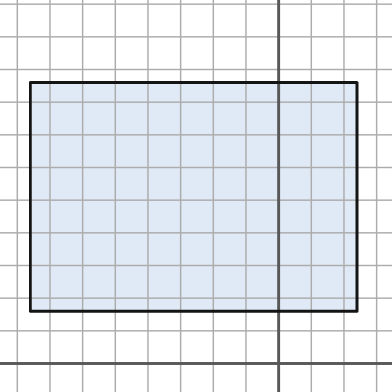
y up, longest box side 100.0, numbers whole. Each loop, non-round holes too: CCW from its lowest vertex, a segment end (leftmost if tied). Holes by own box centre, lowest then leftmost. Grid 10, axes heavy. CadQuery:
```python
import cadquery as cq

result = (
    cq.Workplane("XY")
    .moveTo(-76.0, 16.0)
    .lineTo(24.0, 16.0)
    .lineTo(24.0, 86.0)
    .lineTo(-76.0, 86.0)
    .close()
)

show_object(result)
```